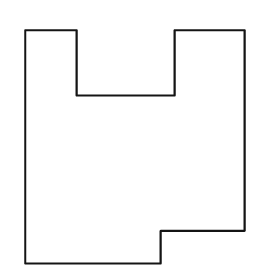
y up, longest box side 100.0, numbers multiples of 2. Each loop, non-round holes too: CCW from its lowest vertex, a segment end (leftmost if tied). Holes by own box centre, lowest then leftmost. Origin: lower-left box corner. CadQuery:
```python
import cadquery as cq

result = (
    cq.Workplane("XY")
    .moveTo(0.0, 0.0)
    .lineTo(58.0, 0.0)
    .lineTo(58.0, 14.0)
    .lineTo(94.0, 14.0)
    .lineTo(94.0, 100.0)
    .lineTo(64.0, 100.0)
    .lineTo(64.0, 72.0)
    .lineTo(22.0, 72.0)
    .lineTo(22.0, 100.0)
    .lineTo(0.0, 100.0)
    .close()
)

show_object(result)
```